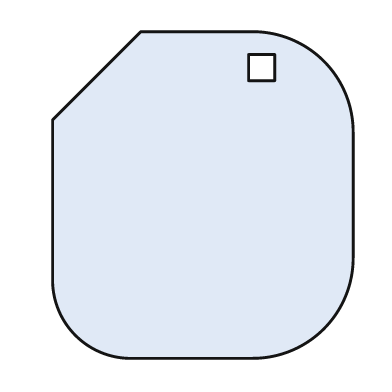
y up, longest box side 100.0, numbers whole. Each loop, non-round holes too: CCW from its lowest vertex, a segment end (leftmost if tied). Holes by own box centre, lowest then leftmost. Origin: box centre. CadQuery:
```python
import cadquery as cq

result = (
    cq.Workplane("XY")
    .moveTo(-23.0, -50.0)
    .lineTo(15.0, -50.0)
    .threePointArc((37.0, -41.0), (46.0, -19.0))
    .lineTo(46.0, 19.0)
    .threePointArc((37.0, 41.0), (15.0, 50.0))
    .lineTo(-19.0, 50.0)
    .lineTo(-46.0, 23.0)
    .lineTo(-46.0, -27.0)
    .threePointArc((-39.0, -43.0), (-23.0, -50.0))
    .close()
    .moveTo(14.0, 35.0)
    .lineTo(22.0, 35.0)
    .lineTo(22.0, 43.0)
    .lineTo(14.0, 43.0)
    .close()
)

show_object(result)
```